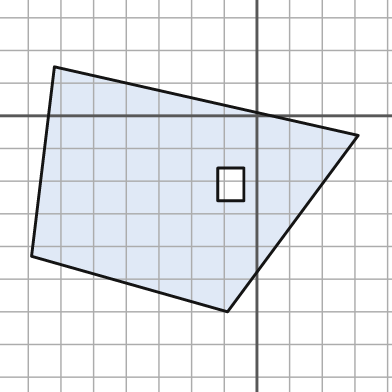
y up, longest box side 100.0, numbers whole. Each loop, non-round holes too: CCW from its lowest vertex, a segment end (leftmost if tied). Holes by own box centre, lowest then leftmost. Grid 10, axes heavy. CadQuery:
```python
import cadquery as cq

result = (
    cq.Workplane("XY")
    .moveTo(-9.0, -60.0)
    .lineTo(31.0, -6.0)
    .lineTo(-62.0, 15.0)
    .lineTo(-69.0, -43.0)
    .close()
    .moveTo(-12.0, -26.0)
    .lineTo(-4.0, -26.0)
    .lineTo(-4.0, -16.0)
    .lineTo(-12.0, -16.0)
    .close()
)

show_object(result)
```